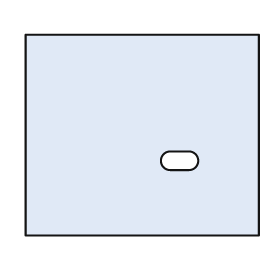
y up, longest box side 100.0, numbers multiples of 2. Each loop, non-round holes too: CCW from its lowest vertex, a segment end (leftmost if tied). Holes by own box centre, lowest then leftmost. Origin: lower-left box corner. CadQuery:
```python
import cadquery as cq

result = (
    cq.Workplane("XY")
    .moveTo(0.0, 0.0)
    .lineTo(100.0, 0.0)
    .lineTo(100.0, 86.0)
    .lineTo(0.0, 86.0)
    .close()
    .moveTo(62.0, 28.0)
    .lineTo(70.0, 28.0)
    .threePointArc((74.0, 32.0), (70.0, 36.0))
    .lineTo(62.0, 36.0)
    .threePointArc((58.0, 32.0), (62.0, 28.0))
    .close()
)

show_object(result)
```